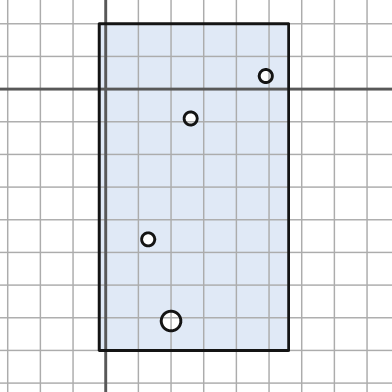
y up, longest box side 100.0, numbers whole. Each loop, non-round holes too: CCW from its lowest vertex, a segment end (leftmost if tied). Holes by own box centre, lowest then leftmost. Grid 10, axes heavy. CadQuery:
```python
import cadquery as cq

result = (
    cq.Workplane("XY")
    .moveTo(-2.0, -80.0)
    .lineTo(56.0, -80.0)
    .lineTo(56.0, 20.0)
    .lineTo(-2.0, 20.0)
    .close()
    .moveTo(20.0, -71.0)
    .circle(3.0)
    .moveTo(13.0, -46.0)
    .circle(2.0)
    .moveTo(26.0, -9.0)
    .circle(2.0)
    .moveTo(49.0, 4.0)
    .circle(2.0)
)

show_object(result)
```